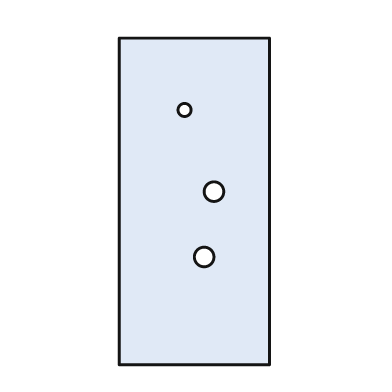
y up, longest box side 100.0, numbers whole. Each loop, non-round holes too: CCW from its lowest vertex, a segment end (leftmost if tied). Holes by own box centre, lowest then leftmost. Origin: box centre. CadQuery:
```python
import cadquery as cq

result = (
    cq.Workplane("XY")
    .moveTo(-23.0, -50.0)
    .lineTo(23.0, -50.0)
    .lineTo(23.0, 50.0)
    .lineTo(-23.0, 50.0)
    .close()
    .moveTo(3.0, -17.0)
    .circle(3.0)
    .moveTo(6.0, 3.0)
    .circle(3.0)
    .moveTo(-3.0, 28.0)
    .circle(2.0)
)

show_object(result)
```